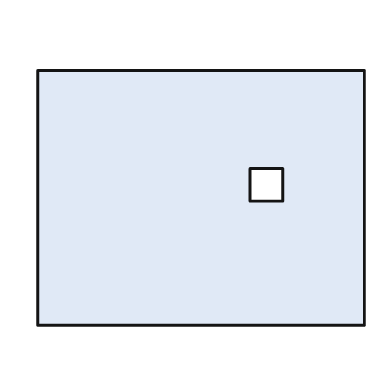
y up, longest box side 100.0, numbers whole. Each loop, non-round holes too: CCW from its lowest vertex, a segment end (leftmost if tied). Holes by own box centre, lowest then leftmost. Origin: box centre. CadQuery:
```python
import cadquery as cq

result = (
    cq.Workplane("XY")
    .moveTo(-50.0, -39.0)
    .lineTo(50.0, -39.0)
    .lineTo(50.0, 39.0)
    .lineTo(-50.0, 39.0)
    .close()
    .moveTo(15.0, -1.0)
    .lineTo(25.0, -1.0)
    .lineTo(25.0, 9.0)
    .lineTo(15.0, 9.0)
    .close()
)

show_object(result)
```